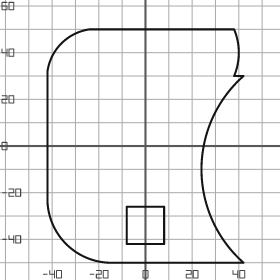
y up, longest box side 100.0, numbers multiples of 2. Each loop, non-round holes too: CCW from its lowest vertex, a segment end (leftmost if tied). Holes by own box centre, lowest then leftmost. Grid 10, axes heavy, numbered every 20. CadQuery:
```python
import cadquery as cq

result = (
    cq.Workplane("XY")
    .moveTo(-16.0, -50.0)
    .lineTo(42.0, -50.0)
    .threePointArc((24.0, -10.0), (42.0, 30.0))
    .lineTo(38.0, 30.0)
    .threePointArc((40.0, 40.0), (38.0, 50.0))
    .lineTo(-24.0, 50.0)
    .threePointArc((-36.0, 44.0), (-42.0, 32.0))
    .lineTo(-42.0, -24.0)
    .threePointArc((-34.0, -42.0), (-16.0, -50.0))
    .close()
    .moveTo(-8.0, -42.0)
    .lineTo(8.0, -42.0)
    .lineTo(8.0, -26.0)
    .lineTo(-8.0, -26.0)
    .close()
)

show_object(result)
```